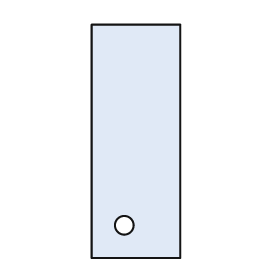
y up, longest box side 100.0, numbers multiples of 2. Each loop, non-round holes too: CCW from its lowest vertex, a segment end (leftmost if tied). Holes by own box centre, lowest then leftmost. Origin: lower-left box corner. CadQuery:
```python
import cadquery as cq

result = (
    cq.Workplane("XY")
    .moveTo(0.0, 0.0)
    .lineTo(38.0, 0.0)
    .lineTo(38.0, 100.0)
    .lineTo(0.0, 100.0)
    .close()
    .moveTo(14.0, 14.0)
    .circle(4.0)
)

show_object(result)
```